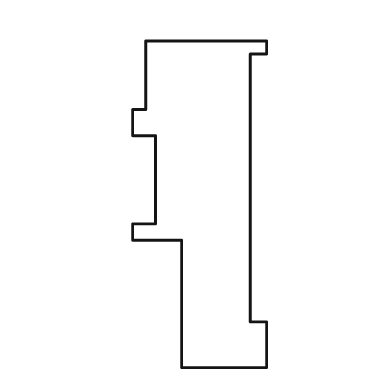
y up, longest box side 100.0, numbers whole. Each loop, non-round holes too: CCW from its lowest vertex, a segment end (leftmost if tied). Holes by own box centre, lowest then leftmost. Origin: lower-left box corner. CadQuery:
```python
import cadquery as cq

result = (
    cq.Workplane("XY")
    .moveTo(15.0, 0.0)
    .lineTo(41.0, 0.0)
    .lineTo(41.0, 14.0)
    .lineTo(36.0, 14.0)
    .lineTo(36.0, 96.0)
    .lineTo(41.0, 96.0)
    .lineTo(41.0, 100.0)
    .lineTo(4.0, 100.0)
    .lineTo(4.0, 79.0)
    .lineTo(0.0, 79.0)
    .lineTo(0.0, 71.0)
    .lineTo(7.0, 71.0)
    .lineTo(7.0, 44.0)
    .lineTo(0.0, 44.0)
    .lineTo(0.0, 39.0)
    .lineTo(15.0, 39.0)
    .close()
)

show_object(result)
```